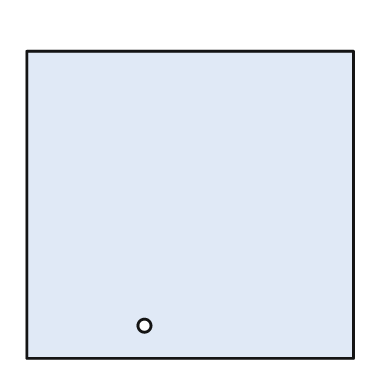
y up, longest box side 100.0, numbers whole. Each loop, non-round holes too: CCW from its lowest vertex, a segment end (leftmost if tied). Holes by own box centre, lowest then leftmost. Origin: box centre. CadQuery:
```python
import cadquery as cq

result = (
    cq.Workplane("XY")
    .moveTo(-50.0, -47.0)
    .lineTo(50.0, -47.0)
    .lineTo(50.0, 47.0)
    .lineTo(-50.0, 47.0)
    .close()
    .moveTo(-14.0, -37.0)
    .circle(2.0)
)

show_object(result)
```